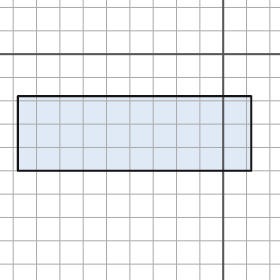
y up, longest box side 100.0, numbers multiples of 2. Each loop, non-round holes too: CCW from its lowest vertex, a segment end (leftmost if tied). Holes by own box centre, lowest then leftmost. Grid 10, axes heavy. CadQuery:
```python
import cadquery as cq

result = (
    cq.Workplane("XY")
    .moveTo(-88.0, -50.0)
    .lineTo(12.0, -50.0)
    .lineTo(12.0, -18.0)
    .lineTo(-88.0, -18.0)
    .close()
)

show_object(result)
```